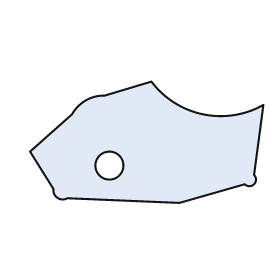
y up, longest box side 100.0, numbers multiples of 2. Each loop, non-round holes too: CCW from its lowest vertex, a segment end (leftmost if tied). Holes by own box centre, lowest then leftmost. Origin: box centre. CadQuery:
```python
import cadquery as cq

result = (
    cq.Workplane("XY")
    .moveTo(14.0, -26.0)
    .lineTo(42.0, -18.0)
    .threePointArc((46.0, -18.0), (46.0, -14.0))
    .lineTo(50.0, 16.0)
    .threePointArc((24.0, 12.0), (2.0, 26.0))
    .lineTo(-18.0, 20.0)
    .threePointArc((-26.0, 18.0), (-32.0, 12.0))
    .lineTo(-50.0, -4.0)
    .lineTo(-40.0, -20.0)
    .threePointArc((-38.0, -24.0), (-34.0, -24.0))
    .close()
    .moveTo(-16.0, -10.0)
    .circle(6.0)
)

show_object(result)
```